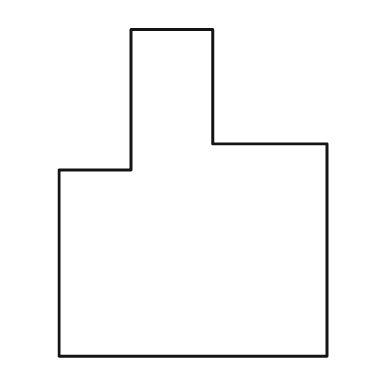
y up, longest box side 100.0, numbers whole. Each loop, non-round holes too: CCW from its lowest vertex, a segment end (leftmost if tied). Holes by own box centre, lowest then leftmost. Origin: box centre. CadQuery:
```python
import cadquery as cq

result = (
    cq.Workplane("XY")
    .moveTo(-41.0, -50.0)
    .lineTo(41.0, -50.0)
    .lineTo(41.0, 15.0)
    .lineTo(6.0, 15.0)
    .lineTo(6.0, 50.0)
    .lineTo(-19.0, 50.0)
    .lineTo(-19.0, 7.0)
    .lineTo(-41.0, 7.0)
    .close()
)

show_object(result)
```